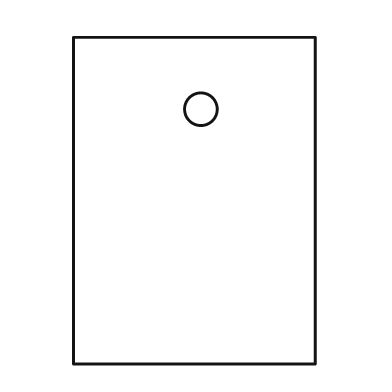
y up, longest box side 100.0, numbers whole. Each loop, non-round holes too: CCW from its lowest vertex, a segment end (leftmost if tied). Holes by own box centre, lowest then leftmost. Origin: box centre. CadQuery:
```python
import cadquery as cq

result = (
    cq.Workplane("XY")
    .moveTo(-37.0, -50.0)
    .lineTo(37.0, -50.0)
    .lineTo(37.0, 50.0)
    .lineTo(-37.0, 50.0)
    .close()
    .moveTo(2.0, 28.0)
    .circle(5.0)
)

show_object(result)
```